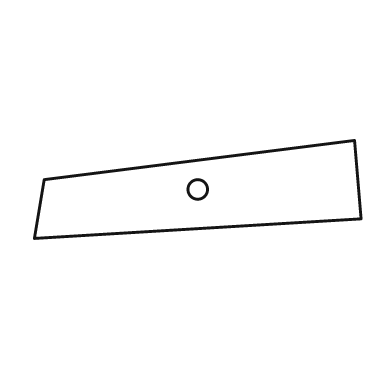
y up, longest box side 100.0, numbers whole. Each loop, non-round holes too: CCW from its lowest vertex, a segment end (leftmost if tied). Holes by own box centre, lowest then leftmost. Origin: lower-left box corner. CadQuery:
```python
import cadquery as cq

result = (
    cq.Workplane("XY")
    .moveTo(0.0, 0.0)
    .lineTo(100.0, 6.0)
    .lineTo(98.0, 30.0)
    .lineTo(3.0, 18.0)
    .close()
    .moveTo(50.0, 15.0)
    .circle(3.0)
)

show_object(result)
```